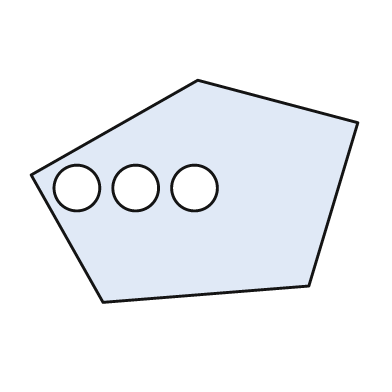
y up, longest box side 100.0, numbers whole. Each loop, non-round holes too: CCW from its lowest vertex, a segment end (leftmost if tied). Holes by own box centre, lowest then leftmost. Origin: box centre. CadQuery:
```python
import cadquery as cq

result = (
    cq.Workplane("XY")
    .moveTo(-28.0, -34.0)
    .lineTo(35.0, -29.0)
    .lineTo(50.0, 21.0)
    .lineTo(1.0, 34.0)
    .lineTo(-50.0, 5.0)
    .close()
    .moveTo(-36.0, 1.0)
    .circle(7.0)
    .moveTo(-18.0, 1.0)
    .circle(7.0)
    .moveTo(0.0, 1.0)
    .circle(7.0)
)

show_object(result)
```